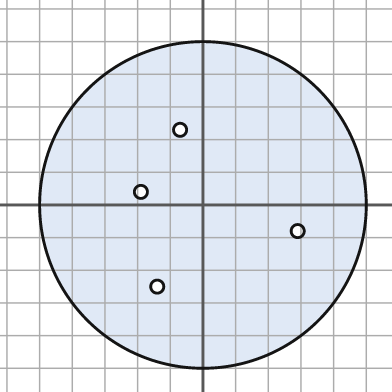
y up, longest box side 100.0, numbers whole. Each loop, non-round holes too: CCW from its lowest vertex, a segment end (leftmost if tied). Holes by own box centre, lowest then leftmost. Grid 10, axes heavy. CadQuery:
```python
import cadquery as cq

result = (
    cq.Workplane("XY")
    .moveTo(0.0, 0.0)
    .circle(50.0)
    .moveTo(-14.0, -25.0)
    .circle(2.0)
    .moveTo(29.0, -8.0)
    .circle(2.0)
    .moveTo(-19.0, 4.0)
    .circle(2.0)
    .moveTo(-7.0, 23.0)
    .circle(2.0)
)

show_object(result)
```